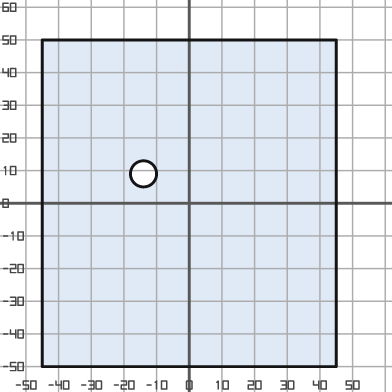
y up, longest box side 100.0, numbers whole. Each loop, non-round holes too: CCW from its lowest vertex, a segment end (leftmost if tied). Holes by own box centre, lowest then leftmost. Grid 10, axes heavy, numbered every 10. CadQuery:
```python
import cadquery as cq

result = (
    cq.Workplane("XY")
    .moveTo(-45.0, -50.0)
    .lineTo(45.0, -50.0)
    .lineTo(45.0, 50.0)
    .lineTo(-45.0, 50.0)
    .close()
    .moveTo(-14.0, 9.0)
    .circle(4.0)
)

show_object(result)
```